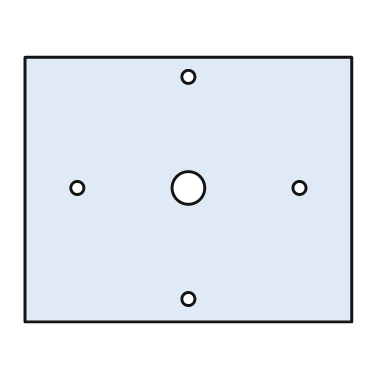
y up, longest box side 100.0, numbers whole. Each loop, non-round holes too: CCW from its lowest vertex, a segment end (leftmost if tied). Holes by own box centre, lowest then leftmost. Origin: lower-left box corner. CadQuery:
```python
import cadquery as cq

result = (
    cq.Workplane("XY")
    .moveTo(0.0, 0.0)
    .lineTo(100.0, 0.0)
    .lineTo(100.0, 81.0)
    .lineTo(0.0, 81.0)
    .close()
    .moveTo(50.0, 7.0)
    .circle(2.0)
    .moveTo(16.0, 41.0)
    .circle(2.0)
    .moveTo(50.0, 41.0)
    .circle(5.0)
    .moveTo(84.0, 41.0)
    .circle(2.0)
    .moveTo(50.0, 75.0)
    .circle(2.0)
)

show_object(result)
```